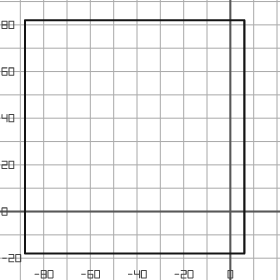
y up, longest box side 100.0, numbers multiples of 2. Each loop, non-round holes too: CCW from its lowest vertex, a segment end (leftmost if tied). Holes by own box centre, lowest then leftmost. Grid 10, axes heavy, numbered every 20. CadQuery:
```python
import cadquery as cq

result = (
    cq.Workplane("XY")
    .moveTo(-88.0, -18.0)
    .lineTo(6.0, -18.0)
    .lineTo(6.0, 82.0)
    .lineTo(-88.0, 82.0)
    .close()
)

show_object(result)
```